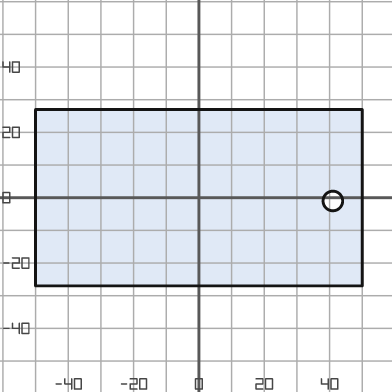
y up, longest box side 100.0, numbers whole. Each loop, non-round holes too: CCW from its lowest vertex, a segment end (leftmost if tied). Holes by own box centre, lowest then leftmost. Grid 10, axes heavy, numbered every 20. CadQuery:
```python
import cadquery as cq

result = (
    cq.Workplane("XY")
    .moveTo(-50.0, -27.0)
    .lineTo(50.0, -27.0)
    .lineTo(50.0, 27.0)
    .lineTo(-50.0, 27.0)
    .close()
    .moveTo(41.0, -1.0)
    .circle(3.0)
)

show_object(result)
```